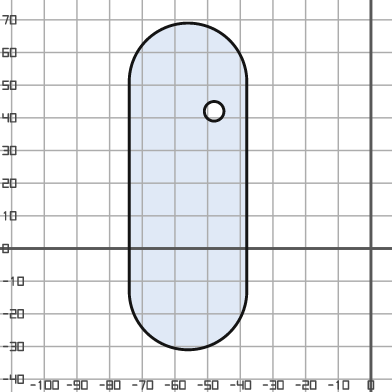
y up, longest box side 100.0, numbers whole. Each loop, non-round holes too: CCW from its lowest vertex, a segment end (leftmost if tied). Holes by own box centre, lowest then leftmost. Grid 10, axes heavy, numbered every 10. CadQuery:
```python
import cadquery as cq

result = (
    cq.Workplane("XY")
    .moveTo(-74.0, -13.0)
    .threePointArc((-56.0, -31.0), (-38.0, -13.0))
    .lineTo(-38.0, 51.0)
    .threePointArc((-56.0, 69.0), (-74.0, 51.0))
    .close()
    .moveTo(-48.0, 42.0)
    .circle(3.0)
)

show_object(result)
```